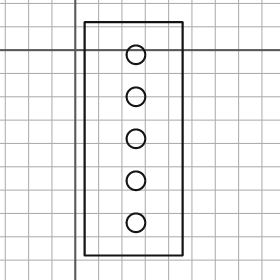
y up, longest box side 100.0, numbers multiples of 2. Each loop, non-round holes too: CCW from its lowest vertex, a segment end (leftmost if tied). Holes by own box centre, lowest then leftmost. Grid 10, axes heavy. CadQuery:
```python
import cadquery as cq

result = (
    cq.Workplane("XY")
    .moveTo(4.0, -88.0)
    .lineTo(46.0, -88.0)
    .lineTo(46.0, 12.0)
    .lineTo(4.0, 12.0)
    .close()
    .moveTo(26.0, -74.0)
    .circle(4.0)
    .moveTo(26.0, -56.0)
    .circle(4.0)
    .moveTo(26.0, -38.0)
    .circle(4.0)
    .moveTo(26.0, -20.0)
    .circle(4.0)
    .moveTo(26.0, -2.0)
    .circle(4.0)
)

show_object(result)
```